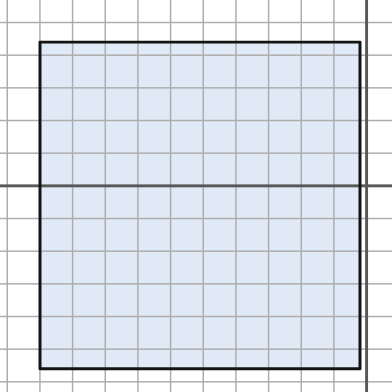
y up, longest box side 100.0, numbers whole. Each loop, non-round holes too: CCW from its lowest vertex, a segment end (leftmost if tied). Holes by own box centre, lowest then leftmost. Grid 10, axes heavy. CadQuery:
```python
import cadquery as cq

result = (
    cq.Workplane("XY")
    .moveTo(-100.0, -56.0)
    .lineTo(-2.0, -56.0)
    .lineTo(-2.0, 44.0)
    .lineTo(-100.0, 44.0)
    .close()
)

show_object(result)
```